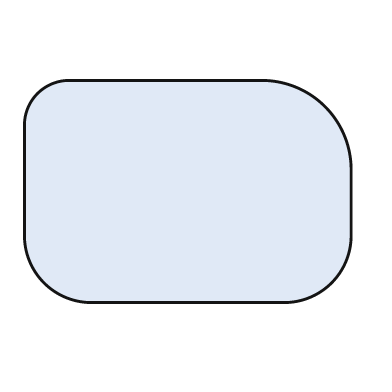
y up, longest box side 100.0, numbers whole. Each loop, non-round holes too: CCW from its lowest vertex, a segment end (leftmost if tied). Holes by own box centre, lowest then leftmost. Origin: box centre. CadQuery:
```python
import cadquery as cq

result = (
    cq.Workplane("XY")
    .moveTo(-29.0, -34.0)
    .lineTo(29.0, -34.0)
    .threePointArc((44.0, -28.0), (50.0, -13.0))
    .lineTo(50.0, 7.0)
    .threePointArc((42.0, 26.0), (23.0, 34.0))
    .lineTo(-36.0, 34.0)
    .threePointArc((-46.0, 30.0), (-50.0, 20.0))
    .lineTo(-50.0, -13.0)
    .threePointArc((-44.0, -28.0), (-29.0, -34.0))
    .close()
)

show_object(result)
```